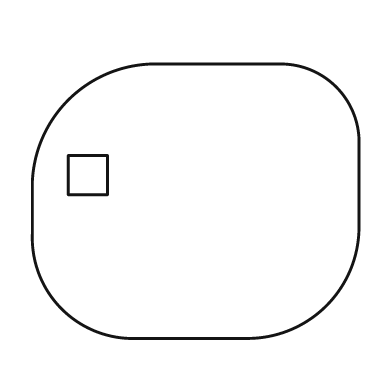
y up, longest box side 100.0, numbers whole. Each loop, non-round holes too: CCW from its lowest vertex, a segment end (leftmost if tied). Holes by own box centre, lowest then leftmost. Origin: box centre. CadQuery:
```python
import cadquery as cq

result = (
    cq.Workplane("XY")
    .moveTo(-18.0, -42.0)
    .lineTo(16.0, -42.0)
    .threePointArc((40.0, -32.0), (50.0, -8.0))
    .lineTo(50.0, 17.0)
    .threePointArc((43.0, 35.0), (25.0, 42.0))
    .lineTo(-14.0, 42.0)
    .threePointArc((-39.0, 31.0), (-50.0, 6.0))
    .lineTo(-50.0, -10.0)
    .threePointArc((-41.0, -33.0), (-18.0, -42.0))
    .close()
    .moveTo(-39.0, 2.0)
    .lineTo(-27.0, 2.0)
    .lineTo(-27.0, 14.0)
    .lineTo(-39.0, 14.0)
    .close()
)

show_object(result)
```